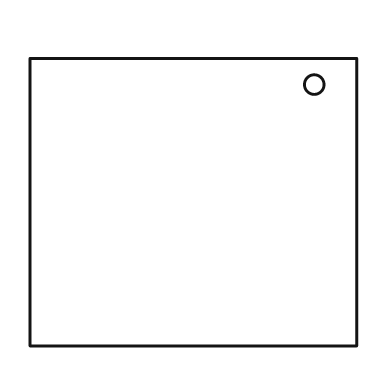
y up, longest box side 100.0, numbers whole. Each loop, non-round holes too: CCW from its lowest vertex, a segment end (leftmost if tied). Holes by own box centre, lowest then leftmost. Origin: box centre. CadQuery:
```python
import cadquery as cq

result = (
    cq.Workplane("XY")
    .moveTo(-50.0, -44.0)
    .lineTo(50.0, -44.0)
    .lineTo(50.0, 44.0)
    .lineTo(-50.0, 44.0)
    .close()
    .moveTo(37.0, 36.0)
    .circle(3.0)
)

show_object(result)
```